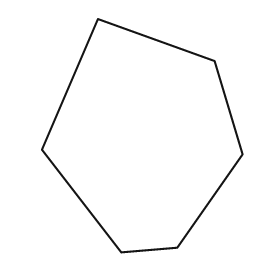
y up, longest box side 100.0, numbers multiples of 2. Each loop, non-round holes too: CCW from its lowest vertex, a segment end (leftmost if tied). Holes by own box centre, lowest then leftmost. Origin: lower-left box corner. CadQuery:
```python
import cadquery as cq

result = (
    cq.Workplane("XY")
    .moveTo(34.0, 0.0)
    .lineTo(58.0, 2.0)
    .lineTo(86.0, 42.0)
    .lineTo(74.0, 82.0)
    .lineTo(24.0, 100.0)
    .lineTo(0.0, 44.0)
    .close()
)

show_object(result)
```